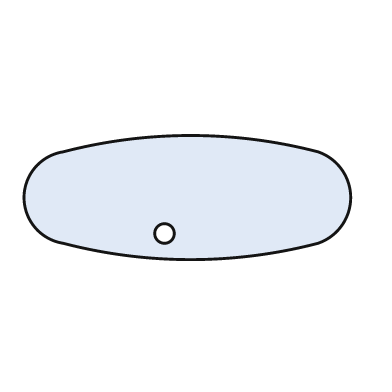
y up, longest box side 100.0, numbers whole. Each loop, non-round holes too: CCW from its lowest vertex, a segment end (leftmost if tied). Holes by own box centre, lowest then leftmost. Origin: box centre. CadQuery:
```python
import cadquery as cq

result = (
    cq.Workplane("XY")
    .moveTo(-38.0, -14.0)
    .threePointArc((1.0, -19.0), (40.0, -14.0))
    .threePointArc((50.0, 0.0), (40.0, 14.0))
    .threePointArc((1.0, 19.0), (-38.0, 14.0))
    .threePointArc((-50.0, 0.0), (-38.0, -14.0))
    .close()
    .moveTo(-7.0, -11.0)
    .circle(3.0)
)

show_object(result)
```